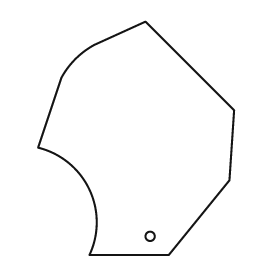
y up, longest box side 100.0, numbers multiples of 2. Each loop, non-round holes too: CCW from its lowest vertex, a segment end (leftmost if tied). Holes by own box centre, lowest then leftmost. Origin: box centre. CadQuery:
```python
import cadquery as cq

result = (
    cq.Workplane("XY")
    .moveTo(-20.0, -50.0)
    .lineTo(14.0, -50.0)
    .lineTo(40.0, -18.0)
    .lineTo(42.0, 12.0)
    .lineTo(4.0, 50.0)
    .lineTo(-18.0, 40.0)
    .threePointArc((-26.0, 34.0), (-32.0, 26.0))
    .lineTo(-42.0, -4.0)
    .threePointArc((-20.0, -22.0), (-20.0, -50.0))
    .close()
    .moveTo(6.0, -42.0)
    .circle(2.0)
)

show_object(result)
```